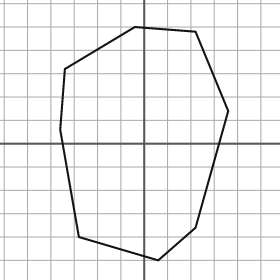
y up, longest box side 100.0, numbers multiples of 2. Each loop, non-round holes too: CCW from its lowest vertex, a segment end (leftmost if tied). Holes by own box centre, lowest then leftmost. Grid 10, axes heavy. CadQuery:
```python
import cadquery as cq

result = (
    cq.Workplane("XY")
    .moveTo(6.0, -50.0)
    .lineTo(22.0, -36.0)
    .lineTo(36.0, 14.0)
    .lineTo(22.0, 48.0)
    .lineTo(-4.0, 50.0)
    .lineTo(-34.0, 32.0)
    .lineTo(-36.0, 6.0)
    .lineTo(-28.0, -40.0)
    .close()
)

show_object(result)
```